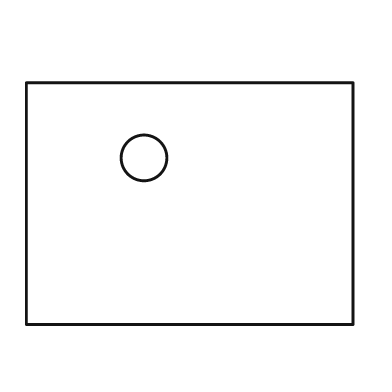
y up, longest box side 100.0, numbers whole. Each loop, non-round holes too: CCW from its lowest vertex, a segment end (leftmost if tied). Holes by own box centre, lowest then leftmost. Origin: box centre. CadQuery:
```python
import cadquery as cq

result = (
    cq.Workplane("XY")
    .moveTo(-50.0, -37.0)
    .lineTo(50.0, -37.0)
    .lineTo(50.0, 37.0)
    .lineTo(-50.0, 37.0)
    .close()
    .moveTo(-14.0, 14.0)
    .circle(7.0)
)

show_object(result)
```